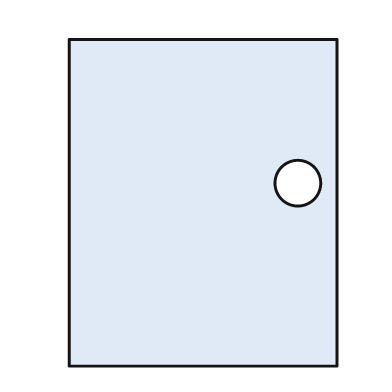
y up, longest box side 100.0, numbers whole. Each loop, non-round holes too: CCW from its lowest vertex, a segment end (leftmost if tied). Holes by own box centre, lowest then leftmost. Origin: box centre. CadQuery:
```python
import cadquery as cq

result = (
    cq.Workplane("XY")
    .moveTo(-41.0, -50.0)
    .lineTo(41.0, -50.0)
    .lineTo(41.0, 50.0)
    .lineTo(-41.0, 50.0)
    .close()
    .moveTo(29.0, 6.0)
    .circle(7.0)
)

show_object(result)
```